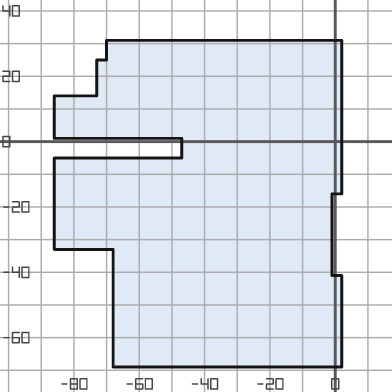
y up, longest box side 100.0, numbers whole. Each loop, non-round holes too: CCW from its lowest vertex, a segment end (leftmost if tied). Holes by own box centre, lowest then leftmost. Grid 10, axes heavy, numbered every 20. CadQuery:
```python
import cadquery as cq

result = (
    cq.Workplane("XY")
    .moveTo(-68.0, -69.0)
    .lineTo(2.0, -69.0)
    .lineTo(2.0, -41.0)
    .lineTo(-1.0, -41.0)
    .lineTo(-1.0, -16.0)
    .lineTo(2.0, -16.0)
    .lineTo(2.0, 31.0)
    .lineTo(-70.0, 31.0)
    .lineTo(-70.0, 25.0)
    .lineTo(-73.0, 25.0)
    .lineTo(-73.0, 14.0)
    .lineTo(-86.0, 14.0)
    .lineTo(-86.0, 1.0)
    .lineTo(-47.0, 1.0)
    .lineTo(-47.0, -5.0)
    .lineTo(-86.0, -5.0)
    .lineTo(-86.0, -33.0)
    .lineTo(-68.0, -33.0)
    .close()
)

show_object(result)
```